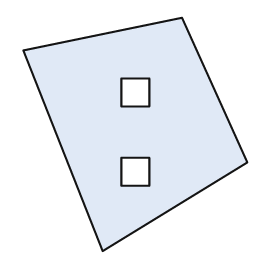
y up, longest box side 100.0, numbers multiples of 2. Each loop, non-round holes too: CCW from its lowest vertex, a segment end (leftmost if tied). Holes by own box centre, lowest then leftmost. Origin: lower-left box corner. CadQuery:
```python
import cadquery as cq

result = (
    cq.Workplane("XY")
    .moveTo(34.0, 0.0)
    .lineTo(96.0, 38.0)
    .lineTo(68.0, 100.0)
    .lineTo(0.0, 86.0)
    .close()
    .moveTo(42.0, 28.0)
    .lineTo(54.0, 28.0)
    .lineTo(54.0, 40.0)
    .lineTo(42.0, 40.0)
    .close()
    .moveTo(42.0, 62.0)
    .lineTo(54.0, 62.0)
    .lineTo(54.0, 74.0)
    .lineTo(42.0, 74.0)
    .close()
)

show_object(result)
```